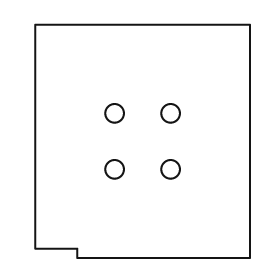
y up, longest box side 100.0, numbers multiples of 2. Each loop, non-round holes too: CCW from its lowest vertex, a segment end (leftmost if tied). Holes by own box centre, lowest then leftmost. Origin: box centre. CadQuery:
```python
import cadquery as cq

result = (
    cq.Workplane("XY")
    .moveTo(-28.0, -50.0)
    .lineTo(46.0, -50.0)
    .lineTo(46.0, 50.0)
    .lineTo(-46.0, 50.0)
    .lineTo(-46.0, -46.0)
    .lineTo(-28.0, -46.0)
    .close()
    .moveTo(-12.0, -12.0)
    .circle(4.0)
    .moveTo(12.0, -12.0)
    .circle(4.0)
    .moveTo(-12.0, 12.0)
    .circle(4.0)
    .moveTo(12.0, 12.0)
    .circle(4.0)
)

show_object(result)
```